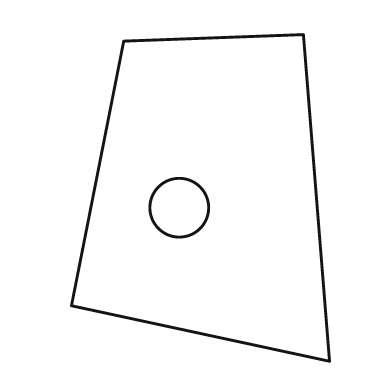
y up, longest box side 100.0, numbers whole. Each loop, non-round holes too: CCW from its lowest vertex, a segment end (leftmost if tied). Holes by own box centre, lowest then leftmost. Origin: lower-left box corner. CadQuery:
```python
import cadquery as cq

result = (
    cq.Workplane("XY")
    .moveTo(79.0, 0.0)
    .lineTo(71.0, 100.0)
    .lineTo(16.0, 98.0)
    .lineTo(0.0, 17.0)
    .close()
    .moveTo(33.0, 47.0)
    .circle(9.0)
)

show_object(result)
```